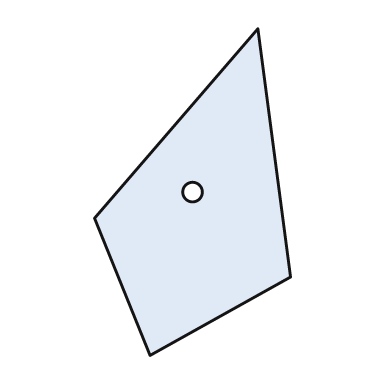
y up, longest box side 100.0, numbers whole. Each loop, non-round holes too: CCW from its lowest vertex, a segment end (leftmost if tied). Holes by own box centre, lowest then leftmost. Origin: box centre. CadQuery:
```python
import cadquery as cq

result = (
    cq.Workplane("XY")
    .moveTo(-13.0, -50.0)
    .lineTo(30.0, -26.0)
    .lineTo(20.0, 50.0)
    .lineTo(-30.0, -8.0)
    .close()
    .moveTo(0.0, 0.0)
    .circle(3.0)
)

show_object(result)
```